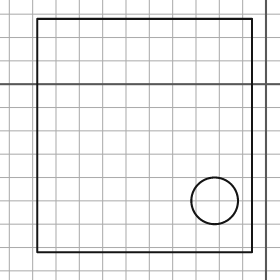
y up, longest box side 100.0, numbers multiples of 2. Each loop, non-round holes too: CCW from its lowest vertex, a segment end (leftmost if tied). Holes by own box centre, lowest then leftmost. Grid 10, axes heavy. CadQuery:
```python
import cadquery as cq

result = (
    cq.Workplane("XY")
    .moveTo(-98.0, -72.0)
    .lineTo(-6.0, -72.0)
    .lineTo(-6.0, 28.0)
    .lineTo(-98.0, 28.0)
    .close()
    .moveTo(-22.0, -50.0)
    .circle(10.0)
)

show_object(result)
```